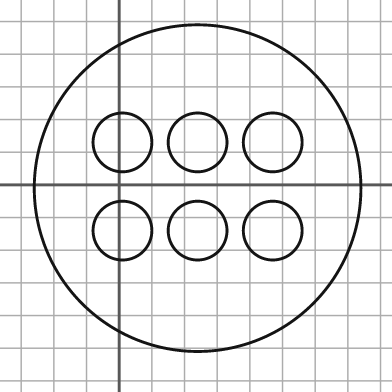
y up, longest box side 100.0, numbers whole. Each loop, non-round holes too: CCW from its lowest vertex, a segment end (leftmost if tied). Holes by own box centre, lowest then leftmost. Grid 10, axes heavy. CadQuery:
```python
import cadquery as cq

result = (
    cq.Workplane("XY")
    .moveTo(24.0, -1.0)
    .circle(50.0)
    .moveTo(1.0, -14.0)
    .circle(9.0)
    .moveTo(24.0, -14.0)
    .circle(9.0)
    .moveTo(47.0, -14.0)
    .circle(9.0)
    .moveTo(1.0, 13.0)
    .circle(9.0)
    .moveTo(24.0, 13.0)
    .circle(9.0)
    .moveTo(47.0, 13.0)
    .circle(9.0)
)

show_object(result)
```